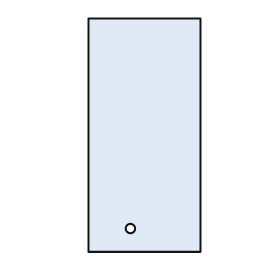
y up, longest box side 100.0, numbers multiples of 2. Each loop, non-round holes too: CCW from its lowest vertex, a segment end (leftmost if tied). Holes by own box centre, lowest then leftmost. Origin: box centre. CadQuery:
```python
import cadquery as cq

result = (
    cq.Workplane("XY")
    .moveTo(-24.0, -50.0)
    .lineTo(24.0, -50.0)
    .lineTo(24.0, 50.0)
    .lineTo(-24.0, 50.0)
    .close()
    .moveTo(-6.0, -40.0)
    .circle(2.0)
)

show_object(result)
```